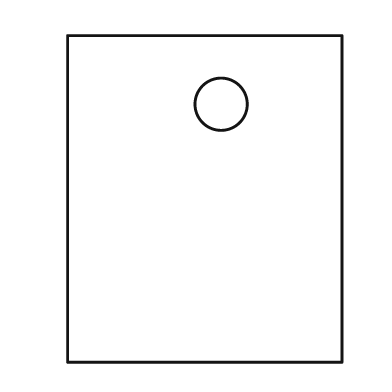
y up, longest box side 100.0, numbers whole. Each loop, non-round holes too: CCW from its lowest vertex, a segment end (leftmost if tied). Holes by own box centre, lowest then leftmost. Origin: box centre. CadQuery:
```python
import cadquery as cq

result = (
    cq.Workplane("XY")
    .moveTo(-42.0, -50.0)
    .lineTo(42.0, -50.0)
    .lineTo(42.0, 50.0)
    .lineTo(-42.0, 50.0)
    .close()
    .moveTo(5.0, 29.0)
    .circle(8.0)
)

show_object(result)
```